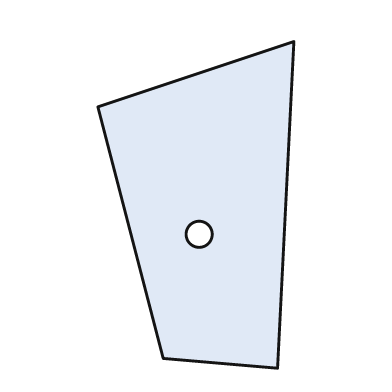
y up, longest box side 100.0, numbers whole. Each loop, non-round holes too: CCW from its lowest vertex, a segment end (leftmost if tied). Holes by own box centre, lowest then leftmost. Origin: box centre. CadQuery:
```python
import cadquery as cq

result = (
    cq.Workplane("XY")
    .moveTo(25.0, -50.0)
    .lineTo(30.0, 50.0)
    .lineTo(-30.0, 30.0)
    .lineTo(-10.0, -47.0)
    .close()
    .moveTo(1.0, -9.0)
    .circle(4.0)
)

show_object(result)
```